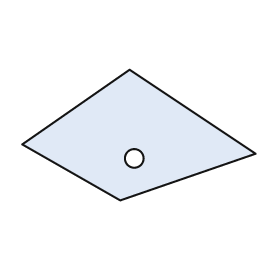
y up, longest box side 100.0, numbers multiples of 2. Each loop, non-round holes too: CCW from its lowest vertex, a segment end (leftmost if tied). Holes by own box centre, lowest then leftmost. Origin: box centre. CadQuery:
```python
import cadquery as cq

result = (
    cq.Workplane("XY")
    .moveTo(-8.0, -28.0)
    .lineTo(50.0, -8.0)
    .lineTo(-4.0, 28.0)
    .lineTo(-50.0, -4.0)
    .close()
    .moveTo(-2.0, -10.0)
    .circle(4.0)
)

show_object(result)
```